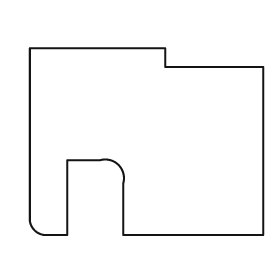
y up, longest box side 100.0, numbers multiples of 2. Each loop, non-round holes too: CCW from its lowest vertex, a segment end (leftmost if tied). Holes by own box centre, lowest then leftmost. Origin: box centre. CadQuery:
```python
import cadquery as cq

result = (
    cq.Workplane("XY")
    .moveTo(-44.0, -40.0)
    .lineTo(-34.0, -40.0)
    .lineTo(-34.0, -8.0)
    .lineTo(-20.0, -8.0)
    .threePointArc((-12.0, -10.0), (-10.0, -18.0))
    .lineTo(-10.0, -40.0)
    .lineTo(50.0, -40.0)
    .lineTo(50.0, 32.0)
    .lineTo(8.0, 32.0)
    .lineTo(8.0, 40.0)
    .lineTo(-50.0, 40.0)
    .lineTo(-50.0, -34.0)
    .threePointArc((-48.0, -38.0), (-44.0, -40.0))
    .close()
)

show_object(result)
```